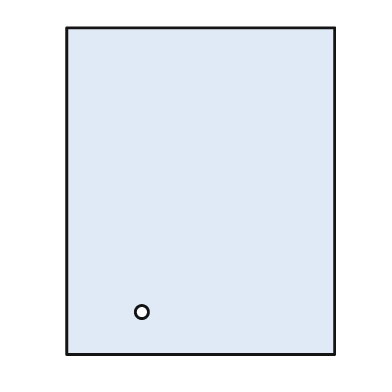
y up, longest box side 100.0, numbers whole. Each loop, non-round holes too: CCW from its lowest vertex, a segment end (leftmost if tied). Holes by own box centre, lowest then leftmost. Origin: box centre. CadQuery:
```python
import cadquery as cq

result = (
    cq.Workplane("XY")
    .moveTo(-41.0, -50.0)
    .lineTo(41.0, -50.0)
    .lineTo(41.0, 50.0)
    .lineTo(-41.0, 50.0)
    .close()
    .moveTo(-18.0, -37.0)
    .circle(2.0)
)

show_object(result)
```